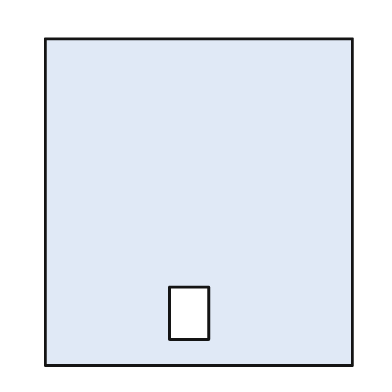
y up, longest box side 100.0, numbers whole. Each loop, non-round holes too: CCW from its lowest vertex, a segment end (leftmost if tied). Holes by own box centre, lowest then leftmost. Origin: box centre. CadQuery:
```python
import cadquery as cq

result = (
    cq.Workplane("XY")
    .moveTo(-47.0, -50.0)
    .lineTo(47.0, -50.0)
    .lineTo(47.0, 50.0)
    .lineTo(-47.0, 50.0)
    .close()
    .moveTo(-9.0, -42.0)
    .lineTo(3.0, -42.0)
    .lineTo(3.0, -26.0)
    .lineTo(-9.0, -26.0)
    .close()
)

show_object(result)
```